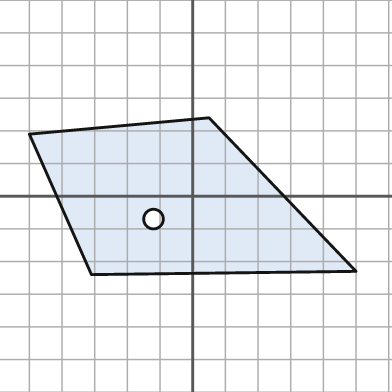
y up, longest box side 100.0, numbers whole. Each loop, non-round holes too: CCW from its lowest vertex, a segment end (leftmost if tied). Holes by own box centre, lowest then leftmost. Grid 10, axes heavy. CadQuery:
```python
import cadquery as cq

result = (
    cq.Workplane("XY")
    .moveTo(-31.0, -24.0)
    .lineTo(50.0, -23.0)
    .lineTo(5.0, 24.0)
    .lineTo(-50.0, 19.0)
    .close()
    .moveTo(-12.0, -7.0)
    .circle(3.0)
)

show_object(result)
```